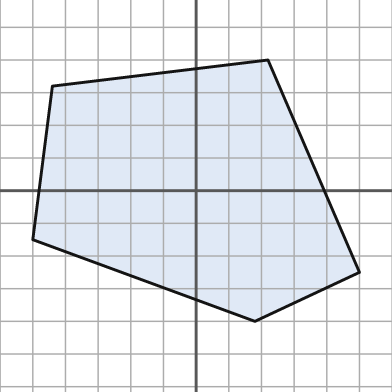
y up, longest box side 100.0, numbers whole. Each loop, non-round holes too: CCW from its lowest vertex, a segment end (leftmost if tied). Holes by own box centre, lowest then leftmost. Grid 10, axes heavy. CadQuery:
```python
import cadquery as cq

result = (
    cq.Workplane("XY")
    .moveTo(18.0, -40.0)
    .lineTo(50.0, -25.0)
    .lineTo(22.0, 40.0)
    .lineTo(-44.0, 32.0)
    .lineTo(-50.0, -15.0)
    .close()
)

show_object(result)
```